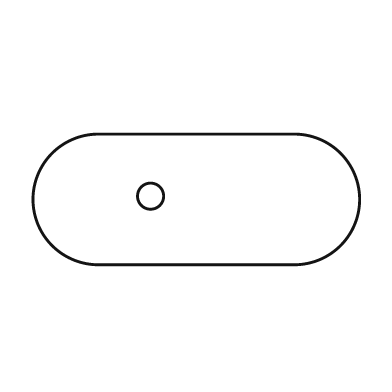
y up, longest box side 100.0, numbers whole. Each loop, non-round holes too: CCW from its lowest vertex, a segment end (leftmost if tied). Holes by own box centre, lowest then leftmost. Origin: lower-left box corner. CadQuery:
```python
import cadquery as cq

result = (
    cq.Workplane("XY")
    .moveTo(20.0, 0.0)
    .lineTo(80.0, 0.0)
    .threePointArc((100.0, 20.0), (80.0, 40.0))
    .lineTo(20.0, 40.0)
    .threePointArc((0.0, 20.0), (20.0, 0.0))
    .close()
    .moveTo(36.0, 21.0)
    .circle(4.0)
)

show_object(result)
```